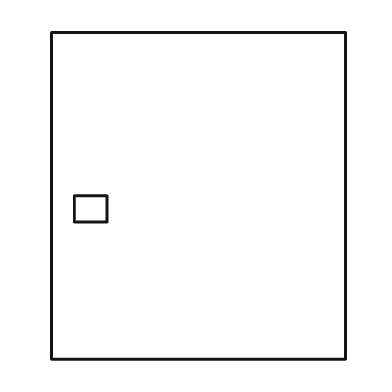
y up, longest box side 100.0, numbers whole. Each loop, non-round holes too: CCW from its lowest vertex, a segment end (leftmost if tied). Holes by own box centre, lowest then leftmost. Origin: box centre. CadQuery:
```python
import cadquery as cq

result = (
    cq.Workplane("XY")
    .moveTo(-45.0, -50.0)
    .lineTo(45.0, -50.0)
    .lineTo(45.0, 50.0)
    .lineTo(-45.0, 50.0)
    .close()
    .moveTo(-38.0, -8.0)
    .lineTo(-28.0, -8.0)
    .lineTo(-28.0, 0.0)
    .lineTo(-38.0, 0.0)
    .close()
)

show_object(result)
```